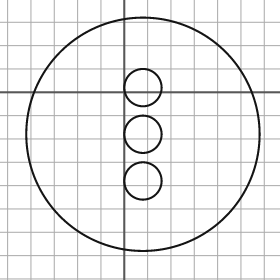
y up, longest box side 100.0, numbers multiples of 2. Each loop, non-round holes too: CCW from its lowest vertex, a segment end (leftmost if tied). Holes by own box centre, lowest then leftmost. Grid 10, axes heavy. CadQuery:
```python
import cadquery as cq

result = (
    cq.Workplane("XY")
    .moveTo(8.0, -18.0)
    .circle(50.0)
    .moveTo(8.0, -38.0)
    .circle(8.0)
    .moveTo(8.0, -18.0)
    .circle(8.0)
    .moveTo(8.0, 2.0)
    .circle(8.0)
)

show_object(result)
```